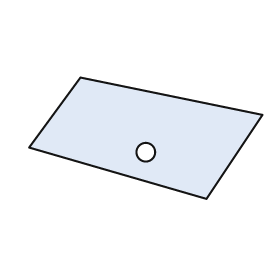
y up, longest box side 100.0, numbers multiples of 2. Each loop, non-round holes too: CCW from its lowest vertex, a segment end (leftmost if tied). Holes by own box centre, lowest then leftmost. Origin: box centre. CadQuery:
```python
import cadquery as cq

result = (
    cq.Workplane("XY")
    .moveTo(26.0, -26.0)
    .lineTo(50.0, 10.0)
    .lineTo(-28.0, 26.0)
    .lineTo(-50.0, -4.0)
    .close()
    .moveTo(0.0, -6.0)
    .circle(4.0)
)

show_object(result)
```